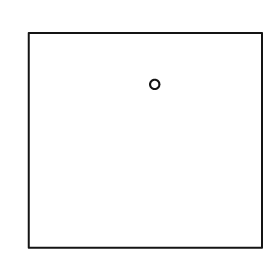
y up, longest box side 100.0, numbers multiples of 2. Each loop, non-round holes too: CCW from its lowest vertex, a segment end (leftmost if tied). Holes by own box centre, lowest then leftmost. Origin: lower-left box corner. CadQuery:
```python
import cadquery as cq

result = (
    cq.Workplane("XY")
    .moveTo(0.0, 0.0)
    .lineTo(100.0, 0.0)
    .lineTo(100.0, 92.0)
    .lineTo(0.0, 92.0)
    .close()
    .moveTo(54.0, 70.0)
    .circle(2.0)
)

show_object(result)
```